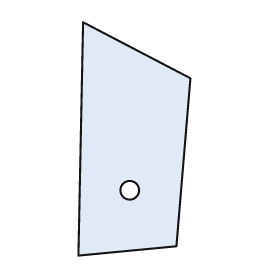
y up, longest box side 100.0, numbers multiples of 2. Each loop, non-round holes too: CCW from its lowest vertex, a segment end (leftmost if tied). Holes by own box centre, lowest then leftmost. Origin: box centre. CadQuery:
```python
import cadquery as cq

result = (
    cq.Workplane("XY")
    .moveTo(-24.0, -50.0)
    .lineTo(18.0, -46.0)
    .lineTo(24.0, 26.0)
    .lineTo(-22.0, 50.0)
    .close()
    .moveTo(-2.0, -22.0)
    .circle(4.0)
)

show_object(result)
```